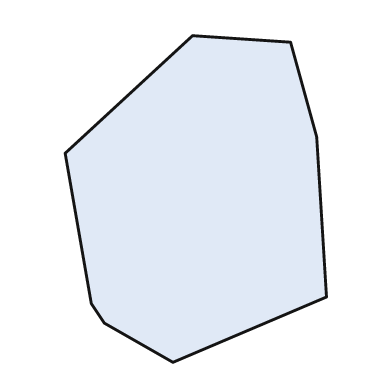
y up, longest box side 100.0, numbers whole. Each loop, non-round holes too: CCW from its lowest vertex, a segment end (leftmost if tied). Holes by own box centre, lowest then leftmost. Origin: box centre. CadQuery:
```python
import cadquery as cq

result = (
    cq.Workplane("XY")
    .moveTo(-7.0, -50.0)
    .lineTo(40.0, -30.0)
    .lineTo(37.0, 19.0)
    .lineTo(29.0, 48.0)
    .lineTo(-1.0, 50.0)
    .lineTo(-40.0, 14.0)
    .lineTo(-32.0, -32.0)
    .lineTo(-28.0, -38.0)
    .close()
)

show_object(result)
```